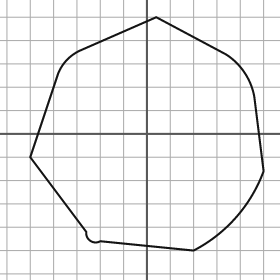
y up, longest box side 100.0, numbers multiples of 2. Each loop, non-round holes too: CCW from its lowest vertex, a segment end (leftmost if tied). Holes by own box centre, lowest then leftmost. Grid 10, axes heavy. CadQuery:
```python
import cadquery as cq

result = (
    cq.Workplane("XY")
    .moveTo(20.0, -50.0)
    .threePointArc((38.0, -36.0), (50.0, -16.0))
    .lineTo(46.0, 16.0)
    .threePointArc((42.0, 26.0), (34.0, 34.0))
    .lineTo(4.0, 50.0)
    .lineTo(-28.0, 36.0)
    .threePointArc((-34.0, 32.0), (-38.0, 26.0))
    .lineTo(-50.0, -10.0)
    .lineTo(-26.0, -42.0)
    .threePointArc((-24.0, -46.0), (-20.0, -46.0))
    .close()
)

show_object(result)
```